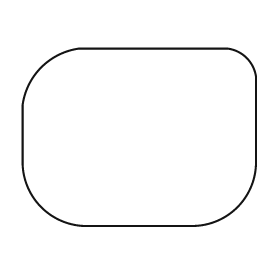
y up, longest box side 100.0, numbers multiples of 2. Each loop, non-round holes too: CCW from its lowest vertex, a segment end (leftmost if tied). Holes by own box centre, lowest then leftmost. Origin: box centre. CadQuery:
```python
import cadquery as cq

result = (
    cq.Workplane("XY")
    .moveTo(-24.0, -38.0)
    .lineTo(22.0, -38.0)
    .threePointArc((42.0, -30.0), (50.0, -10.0))
    .lineTo(50.0, 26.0)
    .threePointArc((46.0, 34.0), (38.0, 38.0))
    .lineTo(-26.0, 38.0)
    .threePointArc((-42.0, 30.0), (-50.0, 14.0))
    .lineTo(-50.0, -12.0)
    .threePointArc((-42.0, -30.0), (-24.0, -38.0))
    .close()
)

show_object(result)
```